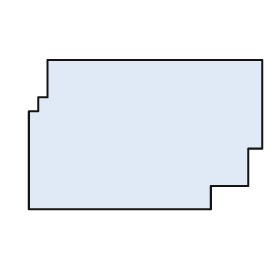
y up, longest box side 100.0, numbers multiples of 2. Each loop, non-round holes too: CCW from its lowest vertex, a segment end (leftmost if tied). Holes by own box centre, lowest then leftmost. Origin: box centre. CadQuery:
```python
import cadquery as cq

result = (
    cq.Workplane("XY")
    .moveTo(-50.0, -32.0)
    .lineTo(28.0, -32.0)
    .lineTo(28.0, -22.0)
    .lineTo(44.0, -22.0)
    .lineTo(44.0, -6.0)
    .lineTo(50.0, -6.0)
    .lineTo(50.0, 32.0)
    .lineTo(-42.0, 32.0)
    .lineTo(-42.0, 16.0)
    .lineTo(-46.0, 16.0)
    .lineTo(-46.0, 10.0)
    .lineTo(-50.0, 10.0)
    .close()
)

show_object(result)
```